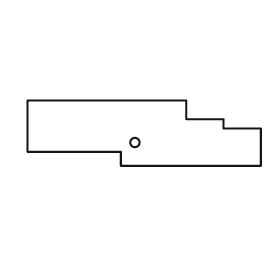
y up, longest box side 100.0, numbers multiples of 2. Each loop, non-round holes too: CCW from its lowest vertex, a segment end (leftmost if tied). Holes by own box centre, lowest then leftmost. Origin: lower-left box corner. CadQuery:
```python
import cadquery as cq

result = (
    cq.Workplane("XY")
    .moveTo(40.0, 0.0)
    .lineTo(100.0, 0.0)
    .lineTo(100.0, 16.0)
    .lineTo(84.0, 16.0)
    .lineTo(84.0, 20.0)
    .lineTo(68.0, 20.0)
    .lineTo(68.0, 28.0)
    .lineTo(0.0, 28.0)
    .lineTo(0.0, 6.0)
    .lineTo(40.0, 6.0)
    .close()
    .moveTo(46.0, 10.0)
    .circle(2.0)
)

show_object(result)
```